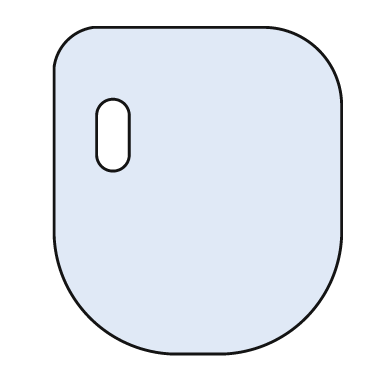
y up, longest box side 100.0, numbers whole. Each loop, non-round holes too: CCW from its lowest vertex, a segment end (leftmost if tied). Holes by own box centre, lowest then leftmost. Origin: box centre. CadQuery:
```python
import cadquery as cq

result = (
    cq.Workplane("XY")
    .moveTo(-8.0, -50.0)
    .lineTo(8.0, -50.0)
    .threePointArc((33.0, -39.0), (44.0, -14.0))
    .lineTo(44.0, 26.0)
    .threePointArc((37.0, 43.0), (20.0, 50.0))
    .lineTo(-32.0, 50.0)
    .threePointArc((-40.0, 46.0), (-44.0, 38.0))
    .lineTo(-44.0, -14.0)
    .threePointArc((-33.0, -39.0), (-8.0, -50.0))
    .close()
    .moveTo(-31.0, 11.0)
    .threePointArc((-26.0, 6.0), (-21.0, 11.0))
    .lineTo(-21.0, 23.0)
    .threePointArc((-26.0, 28.0), (-31.0, 23.0))
    .close()
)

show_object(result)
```